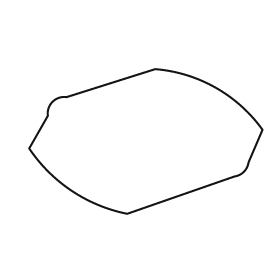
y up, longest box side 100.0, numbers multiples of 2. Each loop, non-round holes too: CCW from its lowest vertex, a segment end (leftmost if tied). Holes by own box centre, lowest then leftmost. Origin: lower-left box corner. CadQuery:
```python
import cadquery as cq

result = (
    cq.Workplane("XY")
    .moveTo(42.0, 0.0)
    .lineTo(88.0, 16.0)
    .threePointArc((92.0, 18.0), (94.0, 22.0))
    .lineTo(100.0, 36.0)
    .threePointArc((80.0, 54.0), (54.0, 62.0))
    .lineTo(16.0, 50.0)
    .threePointArc((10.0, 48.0), (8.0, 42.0))
    .lineTo(0.0, 28.0)
    .threePointArc((18.0, 10.0), (42.0, 0.0))
    .close()
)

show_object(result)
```